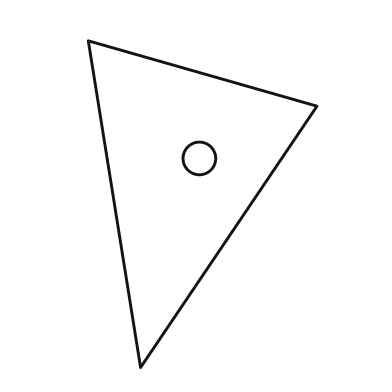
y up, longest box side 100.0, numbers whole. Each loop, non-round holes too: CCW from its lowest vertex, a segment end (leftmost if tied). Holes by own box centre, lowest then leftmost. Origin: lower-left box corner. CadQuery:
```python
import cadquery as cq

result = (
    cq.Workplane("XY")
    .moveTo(16.0, 0.0)
    .lineTo(70.0, 80.0)
    .lineTo(0.0, 100.0)
    .close()
    .moveTo(34.0, 64.0)
    .circle(5.0)
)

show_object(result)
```